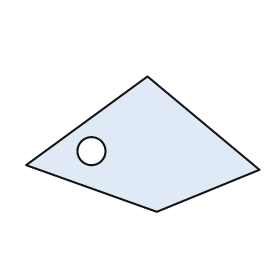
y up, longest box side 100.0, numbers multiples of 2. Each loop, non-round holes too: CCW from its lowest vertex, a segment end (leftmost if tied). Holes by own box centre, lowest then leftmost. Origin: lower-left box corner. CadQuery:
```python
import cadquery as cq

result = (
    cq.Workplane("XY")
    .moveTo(56.0, 0.0)
    .lineTo(100.0, 18.0)
    .lineTo(52.0, 58.0)
    .lineTo(0.0, 20.0)
    .close()
    .moveTo(28.0, 26.0)
    .circle(6.0)
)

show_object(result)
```